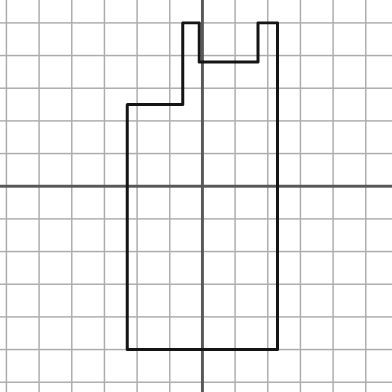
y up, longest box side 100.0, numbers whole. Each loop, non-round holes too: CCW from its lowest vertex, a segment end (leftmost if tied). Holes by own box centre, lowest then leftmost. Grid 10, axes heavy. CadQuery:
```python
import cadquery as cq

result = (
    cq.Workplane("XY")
    .moveTo(-23.0, -50.0)
    .lineTo(23.0, -50.0)
    .lineTo(23.0, 50.0)
    .lineTo(17.0, 50.0)
    .lineTo(17.0, 38.0)
    .lineTo(-1.0, 38.0)
    .lineTo(-1.0, 50.0)
    .lineTo(-6.0, 50.0)
    .lineTo(-6.0, 25.0)
    .lineTo(-23.0, 25.0)
    .close()
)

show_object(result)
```